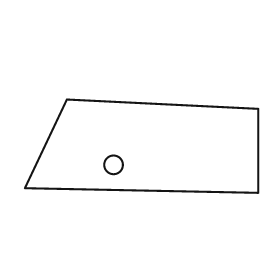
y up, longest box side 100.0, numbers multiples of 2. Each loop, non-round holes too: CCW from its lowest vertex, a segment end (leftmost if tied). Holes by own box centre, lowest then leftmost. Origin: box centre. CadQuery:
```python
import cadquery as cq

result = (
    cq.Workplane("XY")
    .moveTo(50.0, -20.0)
    .lineTo(50.0, 16.0)
    .lineTo(-32.0, 20.0)
    .lineTo(-50.0, -18.0)
    .close()
    .moveTo(-12.0, -8.0)
    .circle(4.0)
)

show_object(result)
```